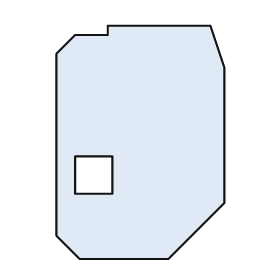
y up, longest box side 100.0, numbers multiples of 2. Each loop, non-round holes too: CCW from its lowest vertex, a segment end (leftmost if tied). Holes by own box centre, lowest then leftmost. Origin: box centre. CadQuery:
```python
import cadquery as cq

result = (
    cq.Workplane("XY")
    .moveTo(-26.0, -50.0)
    .lineTo(12.0, -50.0)
    .lineTo(36.0, -26.0)
    .lineTo(36.0, 32.0)
    .lineTo(30.0, 50.0)
    .lineTo(-14.0, 50.0)
    .lineTo(-14.0, 46.0)
    .lineTo(-28.0, 46.0)
    .lineTo(-36.0, 38.0)
    .lineTo(-36.0, -40.0)
    .close()
    .moveTo(-28.0, -22.0)
    .lineTo(-12.0, -22.0)
    .lineTo(-12.0, -6.0)
    .lineTo(-28.0, -6.0)
    .close()
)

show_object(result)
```